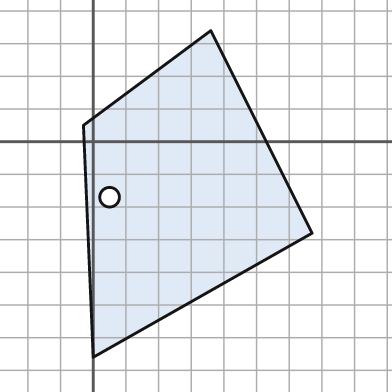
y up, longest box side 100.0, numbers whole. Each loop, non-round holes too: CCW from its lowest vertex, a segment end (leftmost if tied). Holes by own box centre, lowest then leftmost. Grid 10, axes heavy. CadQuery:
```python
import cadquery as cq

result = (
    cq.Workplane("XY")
    .moveTo(0.0, -66.0)
    .lineTo(67.0, -28.0)
    .lineTo(36.0, 34.0)
    .lineTo(-3.0, 5.0)
    .close()
    .moveTo(5.0, -17.0)
    .circle(3.0)
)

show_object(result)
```